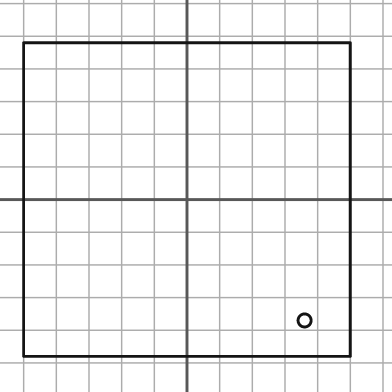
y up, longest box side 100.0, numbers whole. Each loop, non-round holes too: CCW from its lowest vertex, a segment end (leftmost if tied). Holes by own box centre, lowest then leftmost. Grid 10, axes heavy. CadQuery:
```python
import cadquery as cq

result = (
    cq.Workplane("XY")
    .moveTo(-50.0, -48.0)
    .lineTo(50.0, -48.0)
    .lineTo(50.0, 48.0)
    .lineTo(-50.0, 48.0)
    .close()
    .moveTo(36.0, -37.0)
    .circle(2.0)
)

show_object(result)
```